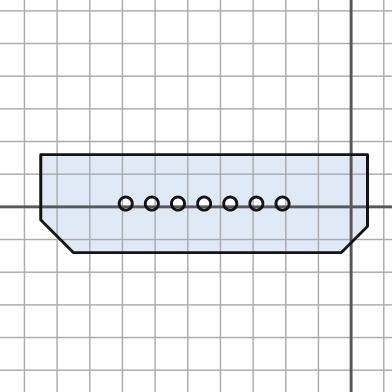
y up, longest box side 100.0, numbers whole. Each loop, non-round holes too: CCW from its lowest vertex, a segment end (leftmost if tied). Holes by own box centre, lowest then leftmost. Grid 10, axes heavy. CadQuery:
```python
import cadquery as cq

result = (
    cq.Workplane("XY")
    .moveTo(-85.0, -14.0)
    .lineTo(-3.0, -14.0)
    .lineTo(5.0, -6.0)
    .lineTo(5.0, 16.0)
    .lineTo(-95.0, 16.0)
    .lineTo(-95.0, -4.0)
    .close()
    .moveTo(-69.0, 1.0)
    .circle(2.0)
    .moveTo(-61.0, 1.0)
    .circle(2.0)
    .moveTo(-53.0, 1.0)
    .circle(2.0)
    .moveTo(-45.0, 1.0)
    .circle(2.0)
    .moveTo(-37.0, 1.0)
    .circle(2.0)
    .moveTo(-29.0, 1.0)
    .circle(2.0)
    .moveTo(-21.0, 1.0)
    .circle(2.0)
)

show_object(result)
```